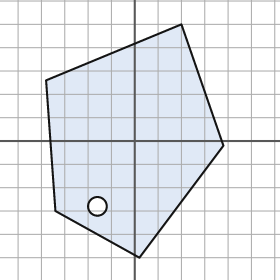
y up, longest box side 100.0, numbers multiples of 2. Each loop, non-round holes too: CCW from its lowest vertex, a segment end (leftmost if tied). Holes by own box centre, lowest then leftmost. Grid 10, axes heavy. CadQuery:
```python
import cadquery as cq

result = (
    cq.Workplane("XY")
    .moveTo(2.0, -50.0)
    .lineTo(38.0, -2.0)
    .lineTo(20.0, 50.0)
    .lineTo(-38.0, 26.0)
    .lineTo(-34.0, -30.0)
    .close()
    .moveTo(-16.0, -28.0)
    .circle(4.0)
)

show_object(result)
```